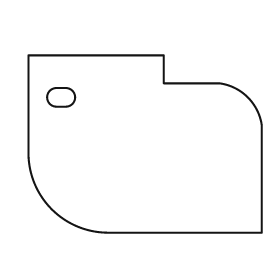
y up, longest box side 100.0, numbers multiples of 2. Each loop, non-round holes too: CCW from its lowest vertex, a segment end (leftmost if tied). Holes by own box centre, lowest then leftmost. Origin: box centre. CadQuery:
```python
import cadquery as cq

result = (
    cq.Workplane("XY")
    .moveTo(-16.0, -38.0)
    .lineTo(50.0, -38.0)
    .lineTo(50.0, 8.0)
    .threePointArc((44.0, 20.0), (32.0, 26.0))
    .lineTo(8.0, 26.0)
    .lineTo(8.0, 38.0)
    .lineTo(-50.0, 38.0)
    .lineTo(-50.0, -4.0)
    .threePointArc((-40.0, -28.0), (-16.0, -38.0))
    .close()
    .moveTo(-38.0, 16.0)
    .lineTo(-34.0, 16.0)
    .threePointArc((-30.0, 20.0), (-34.0, 24.0))
    .lineTo(-38.0, 24.0)
    .threePointArc((-42.0, 20.0), (-38.0, 16.0))
    .close()
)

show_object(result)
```